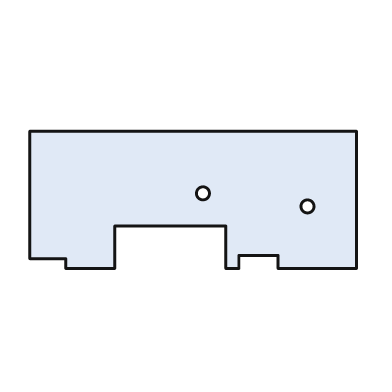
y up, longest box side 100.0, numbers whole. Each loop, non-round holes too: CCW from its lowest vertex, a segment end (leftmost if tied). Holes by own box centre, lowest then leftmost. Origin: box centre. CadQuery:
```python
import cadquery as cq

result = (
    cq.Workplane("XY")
    .moveTo(-39.0, -21.0)
    .lineTo(-24.0, -21.0)
    .lineTo(-24.0, -8.0)
    .lineTo(10.0, -8.0)
    .lineTo(10.0, -21.0)
    .lineTo(14.0, -21.0)
    .lineTo(14.0, -17.0)
    .lineTo(26.0, -17.0)
    .lineTo(26.0, -21.0)
    .lineTo(50.0, -21.0)
    .lineTo(50.0, 21.0)
    .lineTo(-50.0, 21.0)
    .lineTo(-50.0, -18.0)
    .lineTo(-39.0, -18.0)
    .close()
    .moveTo(35.0, -2.0)
    .circle(2.0)
    .moveTo(3.0, 2.0)
    .circle(2.0)
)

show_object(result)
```